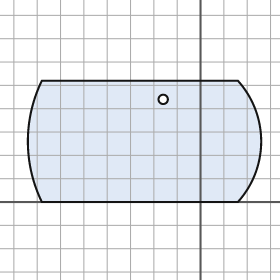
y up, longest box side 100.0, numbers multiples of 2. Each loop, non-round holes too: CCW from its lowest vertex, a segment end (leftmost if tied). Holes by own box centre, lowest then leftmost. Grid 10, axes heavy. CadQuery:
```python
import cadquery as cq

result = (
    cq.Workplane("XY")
    .moveTo(-68.0, 0.0)
    .lineTo(16.0, 0.0)
    .threePointArc((26.0, 26.0), (16.0, 52.0))
    .lineTo(-68.0, 52.0)
    .threePointArc((-74.0, 26.0), (-68.0, 0.0))
    .close()
    .moveTo(-16.0, 44.0)
    .circle(2.0)
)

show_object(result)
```